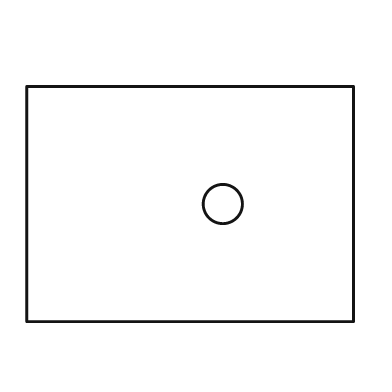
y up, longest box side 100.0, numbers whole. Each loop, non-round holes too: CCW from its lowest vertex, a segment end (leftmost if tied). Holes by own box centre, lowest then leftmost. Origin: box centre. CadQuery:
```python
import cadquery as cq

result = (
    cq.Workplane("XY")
    .moveTo(-50.0, -36.0)
    .lineTo(50.0, -36.0)
    .lineTo(50.0, 36.0)
    .lineTo(-50.0, 36.0)
    .close()
    .moveTo(10.0, 0.0)
    .circle(6.0)
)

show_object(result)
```